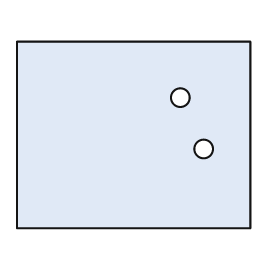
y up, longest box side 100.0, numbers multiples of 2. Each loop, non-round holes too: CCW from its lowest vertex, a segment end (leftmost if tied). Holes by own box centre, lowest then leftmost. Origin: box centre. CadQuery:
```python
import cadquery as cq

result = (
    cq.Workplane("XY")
    .moveTo(-50.0, -40.0)
    .lineTo(50.0, -40.0)
    .lineTo(50.0, 40.0)
    .lineTo(-50.0, 40.0)
    .close()
    .moveTo(30.0, -6.0)
    .circle(4.0)
    .moveTo(20.0, 16.0)
    .circle(4.0)
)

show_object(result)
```